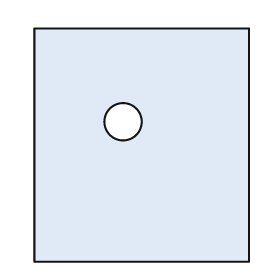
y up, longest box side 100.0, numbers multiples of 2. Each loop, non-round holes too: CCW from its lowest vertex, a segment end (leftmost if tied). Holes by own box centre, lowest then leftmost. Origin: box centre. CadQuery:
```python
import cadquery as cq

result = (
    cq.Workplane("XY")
    .moveTo(-46.0, -50.0)
    .lineTo(46.0, -50.0)
    .lineTo(46.0, 50.0)
    .lineTo(-46.0, 50.0)
    .close()
    .moveTo(-8.0, 10.0)
    .circle(8.0)
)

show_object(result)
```